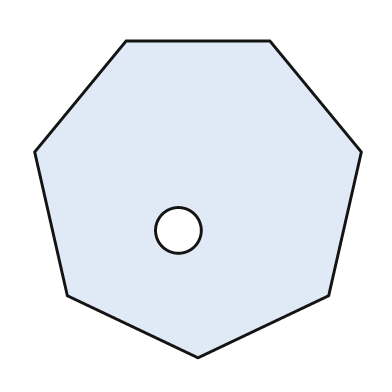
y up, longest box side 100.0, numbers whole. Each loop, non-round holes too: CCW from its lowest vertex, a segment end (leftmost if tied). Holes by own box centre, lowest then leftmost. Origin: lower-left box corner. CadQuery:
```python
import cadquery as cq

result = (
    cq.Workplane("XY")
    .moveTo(50.0, 0.0)
    .lineTo(90.0, 19.0)
    .lineTo(100.0, 63.0)
    .lineTo(72.0, 97.0)
    .lineTo(28.0, 97.0)
    .lineTo(0.0, 63.0)
    .lineTo(10.0, 19.0)
    .close()
    .moveTo(44.0, 39.0)
    .circle(7.0)
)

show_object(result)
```